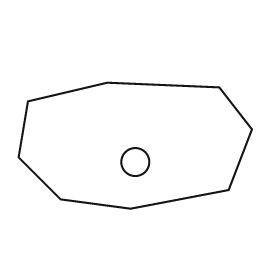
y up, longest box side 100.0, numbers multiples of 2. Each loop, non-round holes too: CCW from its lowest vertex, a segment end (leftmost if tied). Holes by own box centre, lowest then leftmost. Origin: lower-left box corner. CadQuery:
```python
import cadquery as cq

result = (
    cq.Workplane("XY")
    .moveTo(48.0, 0.0)
    .lineTo(90.0, 8.0)
    .lineTo(100.0, 34.0)
    .lineTo(86.0, 52.0)
    .lineTo(38.0, 54.0)
    .lineTo(4.0, 46.0)
    .lineTo(0.0, 22.0)
    .lineTo(18.0, 4.0)
    .close()
    .moveTo(50.0, 20.0)
    .circle(6.0)
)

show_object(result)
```